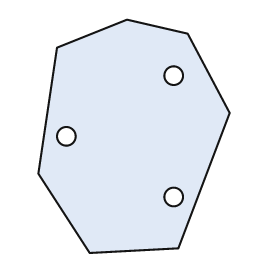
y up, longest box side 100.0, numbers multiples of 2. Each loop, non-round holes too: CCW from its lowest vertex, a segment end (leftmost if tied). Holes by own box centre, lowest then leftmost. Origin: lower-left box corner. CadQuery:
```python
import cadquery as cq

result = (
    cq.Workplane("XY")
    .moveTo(22.0, 0.0)
    .lineTo(60.0, 2.0)
    .lineTo(82.0, 60.0)
    .lineTo(64.0, 94.0)
    .lineTo(38.0, 100.0)
    .lineTo(8.0, 88.0)
    .lineTo(0.0, 34.0)
    .close()
    .moveTo(58.0, 24.0)
    .circle(4.0)
    .moveTo(12.0, 50.0)
    .circle(4.0)
    .moveTo(58.0, 76.0)
    .circle(4.0)
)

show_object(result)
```